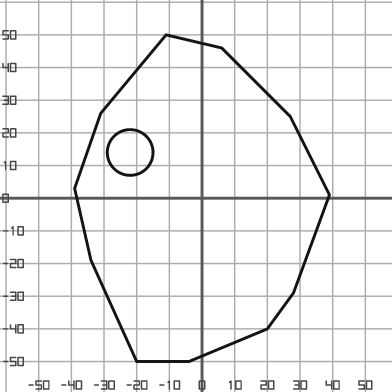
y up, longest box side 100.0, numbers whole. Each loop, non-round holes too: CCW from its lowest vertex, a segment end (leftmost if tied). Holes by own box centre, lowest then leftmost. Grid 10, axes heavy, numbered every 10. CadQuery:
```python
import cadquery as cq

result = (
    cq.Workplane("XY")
    .moveTo(-20.0, -50.0)
    .lineTo(-4.0, -50.0)
    .lineTo(20.0, -40.0)
    .lineTo(28.0, -29.0)
    .lineTo(39.0, 1.0)
    .lineTo(27.0, 25.0)
    .lineTo(6.0, 46.0)
    .lineTo(-11.0, 50.0)
    .lineTo(-31.0, 26.0)
    .lineTo(-39.0, 3.0)
    .lineTo(-34.0, -19.0)
    .close()
    .moveTo(-22.0, 14.0)
    .circle(7.0)
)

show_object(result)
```